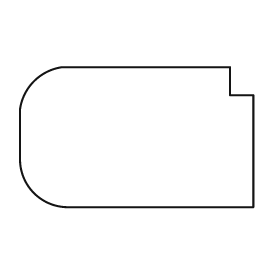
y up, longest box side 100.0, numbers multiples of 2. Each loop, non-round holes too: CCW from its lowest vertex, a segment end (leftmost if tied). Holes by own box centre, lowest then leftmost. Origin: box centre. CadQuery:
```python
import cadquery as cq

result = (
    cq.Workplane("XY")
    .moveTo(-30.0, -30.0)
    .lineTo(50.0, -30.0)
    .lineTo(50.0, 18.0)
    .lineTo(40.0, 18.0)
    .lineTo(40.0, 30.0)
    .lineTo(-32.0, 30.0)
    .threePointArc((-44.0, 24.0), (-50.0, 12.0))
    .lineTo(-50.0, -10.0)
    .threePointArc((-44.0, -24.0), (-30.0, -30.0))
    .close()
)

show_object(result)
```